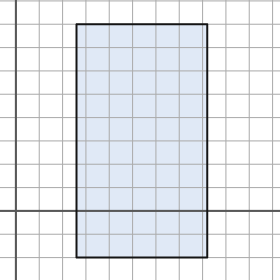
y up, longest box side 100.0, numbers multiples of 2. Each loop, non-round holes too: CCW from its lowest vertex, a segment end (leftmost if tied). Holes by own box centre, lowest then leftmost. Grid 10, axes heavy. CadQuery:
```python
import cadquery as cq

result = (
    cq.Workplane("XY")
    .moveTo(26.0, -20.0)
    .lineTo(82.0, -20.0)
    .lineTo(82.0, 80.0)
    .lineTo(26.0, 80.0)
    .close()
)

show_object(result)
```